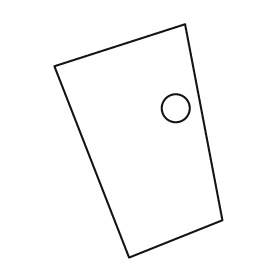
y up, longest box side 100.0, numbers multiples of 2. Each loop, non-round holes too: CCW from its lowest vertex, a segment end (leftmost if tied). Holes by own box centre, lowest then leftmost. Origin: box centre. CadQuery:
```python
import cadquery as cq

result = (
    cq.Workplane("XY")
    .moveTo(-4.0, -50.0)
    .lineTo(36.0, -34.0)
    .lineTo(20.0, 50.0)
    .lineTo(-36.0, 32.0)
    .close()
    .moveTo(16.0, 14.0)
    .circle(6.0)
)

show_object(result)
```